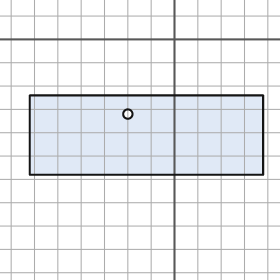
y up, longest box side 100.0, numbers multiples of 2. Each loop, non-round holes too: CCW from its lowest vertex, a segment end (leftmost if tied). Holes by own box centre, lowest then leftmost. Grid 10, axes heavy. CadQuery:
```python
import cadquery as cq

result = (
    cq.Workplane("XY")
    .moveTo(-62.0, -58.0)
    .lineTo(38.0, -58.0)
    .lineTo(38.0, -24.0)
    .lineTo(-62.0, -24.0)
    .close()
    .moveTo(-20.0, -32.0)
    .circle(2.0)
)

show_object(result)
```